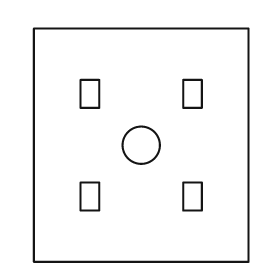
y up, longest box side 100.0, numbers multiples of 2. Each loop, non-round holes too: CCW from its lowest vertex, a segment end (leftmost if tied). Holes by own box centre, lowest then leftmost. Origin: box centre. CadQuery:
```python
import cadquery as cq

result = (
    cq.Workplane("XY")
    .moveTo(-46.0, -50.0)
    .lineTo(46.0, -50.0)
    .lineTo(46.0, 50.0)
    .lineTo(-46.0, 50.0)
    .close()
    .moveTo(-26.0, -28.0)
    .lineTo(-18.0, -28.0)
    .lineTo(-18.0, -16.0)
    .lineTo(-26.0, -16.0)
    .close()
    .moveTo(18.0, -28.0)
    .lineTo(26.0, -28.0)
    .lineTo(26.0, -16.0)
    .lineTo(18.0, -16.0)
    .close()
    .moveTo(0.0, 0.0)
    .circle(8.0)
    .moveTo(-26.0, 16.0)
    .lineTo(-18.0, 16.0)
    .lineTo(-18.0, 28.0)
    .lineTo(-26.0, 28.0)
    .close()
    .moveTo(18.0, 16.0)
    .lineTo(26.0, 16.0)
    .lineTo(26.0, 28.0)
    .lineTo(18.0, 28.0)
    .close()
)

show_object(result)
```